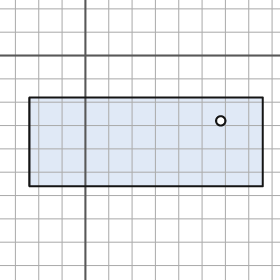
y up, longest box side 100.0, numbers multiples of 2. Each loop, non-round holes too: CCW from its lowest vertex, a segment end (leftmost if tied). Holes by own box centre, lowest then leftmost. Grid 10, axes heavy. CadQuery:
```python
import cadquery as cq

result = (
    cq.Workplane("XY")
    .moveTo(-24.0, -56.0)
    .lineTo(76.0, -56.0)
    .lineTo(76.0, -18.0)
    .lineTo(-24.0, -18.0)
    .close()
    .moveTo(58.0, -28.0)
    .circle(2.0)
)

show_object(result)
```